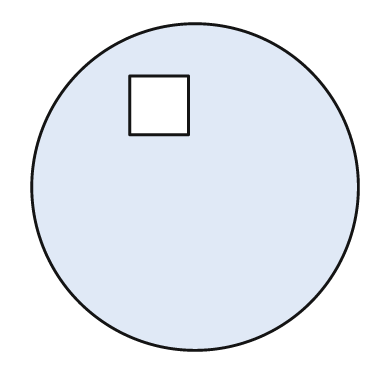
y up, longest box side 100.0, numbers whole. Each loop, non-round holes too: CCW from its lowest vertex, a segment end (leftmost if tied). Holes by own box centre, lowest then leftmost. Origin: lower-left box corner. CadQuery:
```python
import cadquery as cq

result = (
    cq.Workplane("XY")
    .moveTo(50.0, 50.0)
    .circle(50.0)
    .moveTo(30.0, 66.0)
    .lineTo(48.0, 66.0)
    .lineTo(48.0, 84.0)
    .lineTo(30.0, 84.0)
    .close()
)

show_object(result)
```